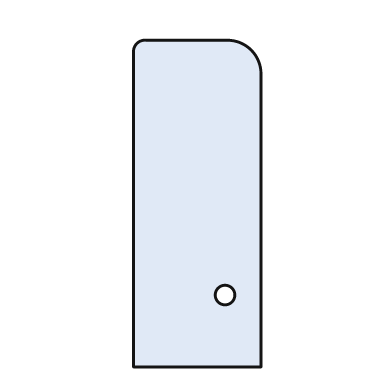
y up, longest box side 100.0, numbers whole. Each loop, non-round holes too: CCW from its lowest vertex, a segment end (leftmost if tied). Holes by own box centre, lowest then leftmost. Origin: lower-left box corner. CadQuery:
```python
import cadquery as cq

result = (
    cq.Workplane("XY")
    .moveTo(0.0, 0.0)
    .lineTo(39.0, 0.0)
    .lineTo(39.0, 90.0)
    .threePointArc((36.0, 97.0), (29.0, 100.0))
    .lineTo(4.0, 100.0)
    .threePointArc((1.0, 99.0), (0.0, 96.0))
    .close()
    .moveTo(28.0, 22.0)
    .circle(3.0)
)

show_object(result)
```